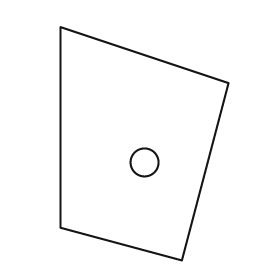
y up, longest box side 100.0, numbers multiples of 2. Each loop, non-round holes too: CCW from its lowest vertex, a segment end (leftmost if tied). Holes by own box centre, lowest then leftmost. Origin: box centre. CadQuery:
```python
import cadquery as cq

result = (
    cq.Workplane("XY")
    .moveTo(16.0, -50.0)
    .lineTo(36.0, 26.0)
    .lineTo(-36.0, 50.0)
    .lineTo(-36.0, -36.0)
    .close()
    .moveTo(0.0, -8.0)
    .circle(6.0)
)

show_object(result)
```